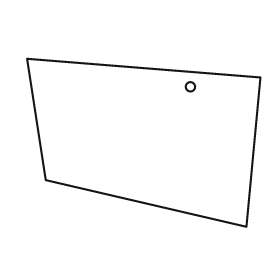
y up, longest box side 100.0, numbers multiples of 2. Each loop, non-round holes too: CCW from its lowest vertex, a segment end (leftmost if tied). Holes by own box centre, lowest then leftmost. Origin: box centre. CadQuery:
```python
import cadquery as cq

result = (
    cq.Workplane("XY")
    .moveTo(44.0, -36.0)
    .lineTo(50.0, 28.0)
    .lineTo(-50.0, 36.0)
    .lineTo(-42.0, -16.0)
    .close()
    .moveTo(20.0, 24.0)
    .circle(2.0)
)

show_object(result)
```